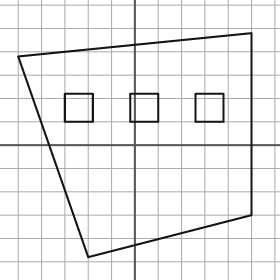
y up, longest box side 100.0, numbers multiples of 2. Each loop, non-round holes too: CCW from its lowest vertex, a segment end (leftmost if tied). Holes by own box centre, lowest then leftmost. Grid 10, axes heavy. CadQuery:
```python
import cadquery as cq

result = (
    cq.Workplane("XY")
    .moveTo(-20.0, -48.0)
    .lineTo(50.0, -30.0)
    .lineTo(50.0, 48.0)
    .lineTo(-50.0, 38.0)
    .close()
    .moveTo(-30.0, 10.0)
    .lineTo(-18.0, 10.0)
    .lineTo(-18.0, 22.0)
    .lineTo(-30.0, 22.0)
    .close()
    .moveTo(-2.0, 10.0)
    .lineTo(10.0, 10.0)
    .lineTo(10.0, 22.0)
    .lineTo(-2.0, 22.0)
    .close()
    .moveTo(26.0, 10.0)
    .lineTo(38.0, 10.0)
    .lineTo(38.0, 22.0)
    .lineTo(26.0, 22.0)
    .close()
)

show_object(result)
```